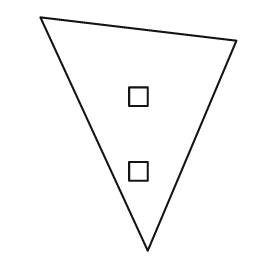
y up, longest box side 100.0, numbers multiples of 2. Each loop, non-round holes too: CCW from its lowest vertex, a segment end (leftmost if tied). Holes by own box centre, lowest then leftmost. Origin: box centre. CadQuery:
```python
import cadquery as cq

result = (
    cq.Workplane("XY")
    .moveTo(4.0, -50.0)
    .lineTo(42.0, 40.0)
    .lineTo(-42.0, 50.0)
    .close()
    .moveTo(-4.0, -20.0)
    .lineTo(4.0, -20.0)
    .lineTo(4.0, -12.0)
    .lineTo(-4.0, -12.0)
    .close()
    .moveTo(-4.0, 12.0)
    .lineTo(4.0, 12.0)
    .lineTo(4.0, 20.0)
    .lineTo(-4.0, 20.0)
    .close()
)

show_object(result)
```